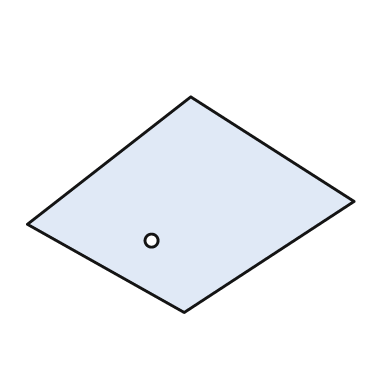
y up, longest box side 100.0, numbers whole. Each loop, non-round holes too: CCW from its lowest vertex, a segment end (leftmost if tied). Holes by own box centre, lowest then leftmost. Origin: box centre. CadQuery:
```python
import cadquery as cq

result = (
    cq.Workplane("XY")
    .moveTo(-2.0, -33.0)
    .lineTo(50.0, 1.0)
    .lineTo(0.0, 33.0)
    .lineTo(-50.0, -6.0)
    .close()
    .moveTo(-12.0, -11.0)
    .circle(2.0)
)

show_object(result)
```